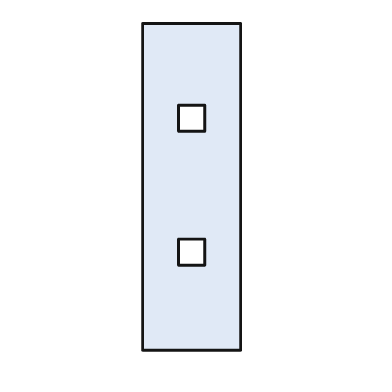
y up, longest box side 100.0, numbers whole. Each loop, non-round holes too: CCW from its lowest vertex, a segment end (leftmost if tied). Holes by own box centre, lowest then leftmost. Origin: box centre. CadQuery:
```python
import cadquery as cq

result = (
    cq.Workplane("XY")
    .moveTo(-15.0, -50.0)
    .lineTo(15.0, -50.0)
    .lineTo(15.0, 50.0)
    .lineTo(-15.0, 50.0)
    .close()
    .moveTo(-4.0, -24.0)
    .lineTo(4.0, -24.0)
    .lineTo(4.0, -16.0)
    .lineTo(-4.0, -16.0)
    .close()
    .moveTo(-4.0, 17.0)
    .lineTo(4.0, 17.0)
    .lineTo(4.0, 25.0)
    .lineTo(-4.0, 25.0)
    .close()
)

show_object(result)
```